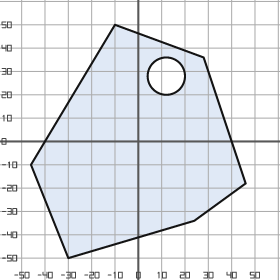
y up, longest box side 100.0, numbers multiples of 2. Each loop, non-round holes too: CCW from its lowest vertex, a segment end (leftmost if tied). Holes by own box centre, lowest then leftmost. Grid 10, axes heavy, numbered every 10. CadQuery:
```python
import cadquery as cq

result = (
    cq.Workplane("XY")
    .moveTo(-30.0, -50.0)
    .lineTo(24.0, -34.0)
    .lineTo(46.0, -18.0)
    .lineTo(28.0, 36.0)
    .lineTo(-10.0, 50.0)
    .lineTo(-46.0, -10.0)
    .close()
    .moveTo(12.0, 28.0)
    .circle(8.0)
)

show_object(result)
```